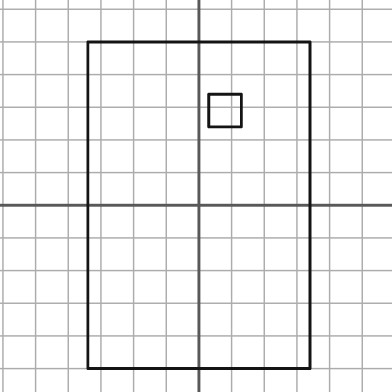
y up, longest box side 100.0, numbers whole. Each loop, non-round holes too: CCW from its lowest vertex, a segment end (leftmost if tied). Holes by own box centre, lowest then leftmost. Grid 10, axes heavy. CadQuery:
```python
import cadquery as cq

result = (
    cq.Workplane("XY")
    .moveTo(-34.0, -50.0)
    .lineTo(34.0, -50.0)
    .lineTo(34.0, 50.0)
    .lineTo(-34.0, 50.0)
    .close()
    .moveTo(3.0, 24.0)
    .lineTo(13.0, 24.0)
    .lineTo(13.0, 34.0)
    .lineTo(3.0, 34.0)
    .close()
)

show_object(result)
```